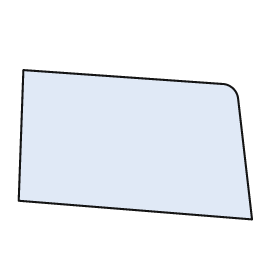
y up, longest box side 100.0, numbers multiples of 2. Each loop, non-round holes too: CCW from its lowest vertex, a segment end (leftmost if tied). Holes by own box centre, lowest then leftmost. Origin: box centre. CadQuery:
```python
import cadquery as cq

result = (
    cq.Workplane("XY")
    .moveTo(50.0, -32.0)
    .lineTo(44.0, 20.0)
    .threePointArc((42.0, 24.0), (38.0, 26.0))
    .lineTo(-48.0, 32.0)
    .lineTo(-50.0, -24.0)
    .close()
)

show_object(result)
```